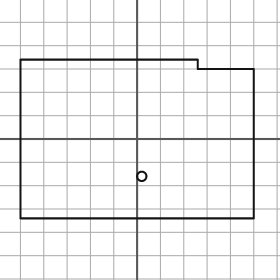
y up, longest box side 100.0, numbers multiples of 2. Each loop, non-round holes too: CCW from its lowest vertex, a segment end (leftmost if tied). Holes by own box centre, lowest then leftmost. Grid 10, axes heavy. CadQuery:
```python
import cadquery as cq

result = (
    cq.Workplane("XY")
    .moveTo(-50.0, -34.0)
    .lineTo(50.0, -34.0)
    .lineTo(50.0, 30.0)
    .lineTo(26.0, 30.0)
    .lineTo(26.0, 34.0)
    .lineTo(-50.0, 34.0)
    .close()
    .moveTo(2.0, -16.0)
    .circle(2.0)
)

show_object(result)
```